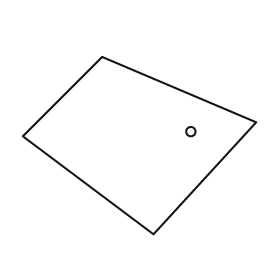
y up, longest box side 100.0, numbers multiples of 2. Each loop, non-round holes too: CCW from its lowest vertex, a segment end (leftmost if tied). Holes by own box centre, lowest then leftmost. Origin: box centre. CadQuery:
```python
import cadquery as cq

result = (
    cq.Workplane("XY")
    .moveTo(6.0, -38.0)
    .lineTo(50.0, 10.0)
    .lineTo(-16.0, 38.0)
    .lineTo(-50.0, 4.0)
    .close()
    .moveTo(22.0, 6.0)
    .circle(2.0)
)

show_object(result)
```